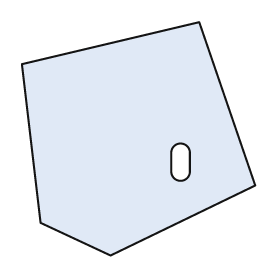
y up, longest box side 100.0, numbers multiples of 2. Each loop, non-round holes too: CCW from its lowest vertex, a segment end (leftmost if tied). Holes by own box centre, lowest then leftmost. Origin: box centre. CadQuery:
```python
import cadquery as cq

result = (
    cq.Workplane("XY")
    .moveTo(-12.0, -50.0)
    .lineTo(50.0, -20.0)
    .lineTo(26.0, 50.0)
    .lineTo(-50.0, 32.0)
    .lineTo(-42.0, -36.0)
    .close()
    .moveTo(14.0, -14.0)
    .threePointArc((18.0, -18.0), (22.0, -14.0))
    .lineTo(22.0, -6.0)
    .threePointArc((18.0, -2.0), (14.0, -6.0))
    .close()
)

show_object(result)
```